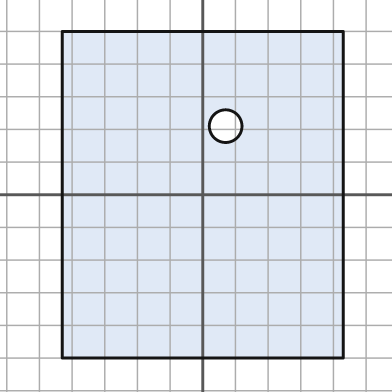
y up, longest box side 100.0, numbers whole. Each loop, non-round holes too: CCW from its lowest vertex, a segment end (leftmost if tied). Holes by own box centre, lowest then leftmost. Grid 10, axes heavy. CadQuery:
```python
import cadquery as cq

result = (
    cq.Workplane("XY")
    .moveTo(-43.0, -50.0)
    .lineTo(43.0, -50.0)
    .lineTo(43.0, 50.0)
    .lineTo(-43.0, 50.0)
    .close()
    .moveTo(7.0, 21.0)
    .circle(5.0)
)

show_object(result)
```